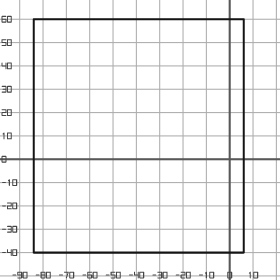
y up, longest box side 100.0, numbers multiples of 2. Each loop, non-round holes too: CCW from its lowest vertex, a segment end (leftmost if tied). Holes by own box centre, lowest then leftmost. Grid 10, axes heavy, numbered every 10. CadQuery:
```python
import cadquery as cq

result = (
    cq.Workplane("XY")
    .moveTo(-84.0, -40.0)
    .lineTo(6.0, -40.0)
    .lineTo(6.0, 60.0)
    .lineTo(-84.0, 60.0)
    .close()
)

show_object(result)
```